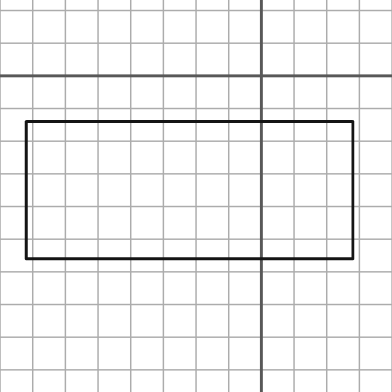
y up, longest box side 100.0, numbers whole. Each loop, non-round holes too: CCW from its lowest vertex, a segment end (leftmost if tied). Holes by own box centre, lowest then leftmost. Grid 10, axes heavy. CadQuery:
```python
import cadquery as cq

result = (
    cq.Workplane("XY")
    .moveTo(-72.0, -56.0)
    .lineTo(28.0, -56.0)
    .lineTo(28.0, -14.0)
    .lineTo(-72.0, -14.0)
    .close()
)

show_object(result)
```